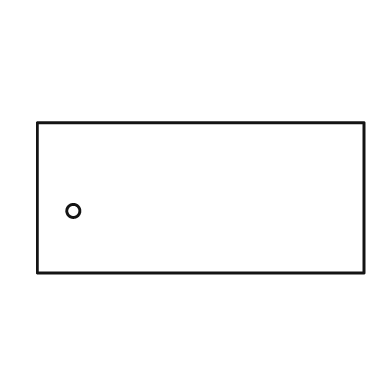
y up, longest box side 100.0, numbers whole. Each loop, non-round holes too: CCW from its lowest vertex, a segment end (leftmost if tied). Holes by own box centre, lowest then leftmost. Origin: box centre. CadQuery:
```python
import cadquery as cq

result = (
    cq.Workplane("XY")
    .moveTo(-50.0, -23.0)
    .lineTo(50.0, -23.0)
    .lineTo(50.0, 23.0)
    .lineTo(-50.0, 23.0)
    .close()
    .moveTo(-39.0, -4.0)
    .circle(2.0)
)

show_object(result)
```